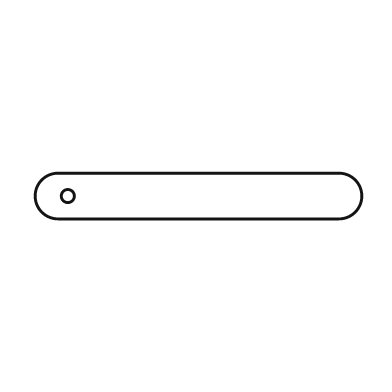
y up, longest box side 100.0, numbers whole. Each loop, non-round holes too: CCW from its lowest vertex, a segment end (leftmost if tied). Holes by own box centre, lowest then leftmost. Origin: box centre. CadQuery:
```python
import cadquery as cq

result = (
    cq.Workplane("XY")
    .moveTo(-43.0, -7.0)
    .lineTo(43.0, -7.0)
    .threePointArc((50.0, 0.0), (43.0, 7.0))
    .lineTo(-43.0, 7.0)
    .threePointArc((-50.0, 0.0), (-43.0, -7.0))
    .close()
    .moveTo(-40.0, 0.0)
    .circle(2.0)
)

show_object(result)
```